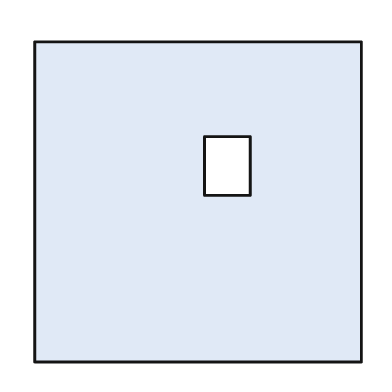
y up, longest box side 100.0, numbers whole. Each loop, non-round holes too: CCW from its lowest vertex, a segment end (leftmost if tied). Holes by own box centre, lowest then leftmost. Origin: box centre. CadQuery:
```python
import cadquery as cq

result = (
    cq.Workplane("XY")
    .moveTo(-50.0, -49.0)
    .lineTo(50.0, -49.0)
    .lineTo(50.0, 49.0)
    .lineTo(-50.0, 49.0)
    .close()
    .moveTo(2.0, 2.0)
    .lineTo(16.0, 2.0)
    .lineTo(16.0, 20.0)
    .lineTo(2.0, 20.0)
    .close()
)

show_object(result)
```